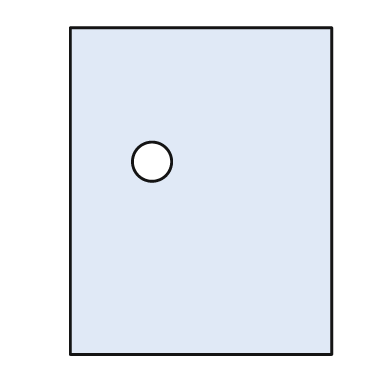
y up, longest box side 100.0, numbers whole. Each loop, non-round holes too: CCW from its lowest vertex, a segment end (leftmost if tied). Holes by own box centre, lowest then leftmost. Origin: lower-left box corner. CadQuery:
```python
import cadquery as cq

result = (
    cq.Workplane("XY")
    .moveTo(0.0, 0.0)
    .lineTo(80.0, 0.0)
    .lineTo(80.0, 100.0)
    .lineTo(0.0, 100.0)
    .close()
    .moveTo(25.0, 59.0)
    .circle(6.0)
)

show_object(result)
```